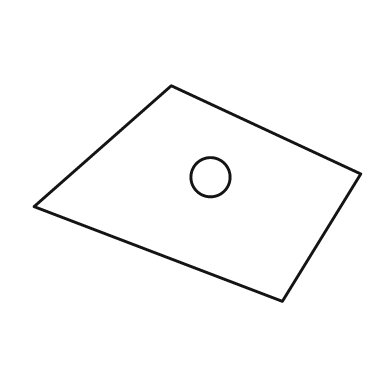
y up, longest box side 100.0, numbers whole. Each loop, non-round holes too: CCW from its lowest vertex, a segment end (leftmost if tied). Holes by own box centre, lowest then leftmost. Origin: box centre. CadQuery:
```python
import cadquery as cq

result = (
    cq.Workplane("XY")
    .moveTo(26.0, -33.0)
    .lineTo(50.0, 6.0)
    .lineTo(-8.0, 33.0)
    .lineTo(-50.0, -4.0)
    .close()
    .moveTo(4.0, 5.0)
    .circle(6.0)
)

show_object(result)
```